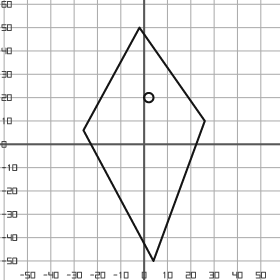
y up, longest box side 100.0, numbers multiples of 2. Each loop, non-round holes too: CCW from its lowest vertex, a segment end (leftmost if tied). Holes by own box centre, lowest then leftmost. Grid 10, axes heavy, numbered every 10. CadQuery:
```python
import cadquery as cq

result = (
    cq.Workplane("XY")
    .moveTo(4.0, -50.0)
    .lineTo(26.0, 10.0)
    .lineTo(-2.0, 50.0)
    .lineTo(-26.0, 6.0)
    .close()
    .moveTo(2.0, 20.0)
    .circle(2.0)
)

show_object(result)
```